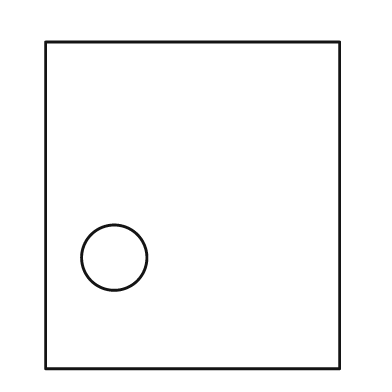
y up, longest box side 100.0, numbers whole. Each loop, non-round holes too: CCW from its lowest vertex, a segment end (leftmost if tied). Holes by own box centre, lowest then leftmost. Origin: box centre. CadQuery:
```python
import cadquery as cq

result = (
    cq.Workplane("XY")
    .moveTo(-45.0, -50.0)
    .lineTo(45.0, -50.0)
    .lineTo(45.0, 50.0)
    .lineTo(-45.0, 50.0)
    .close()
    .moveTo(-24.0, -16.0)
    .circle(10.0)
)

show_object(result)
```